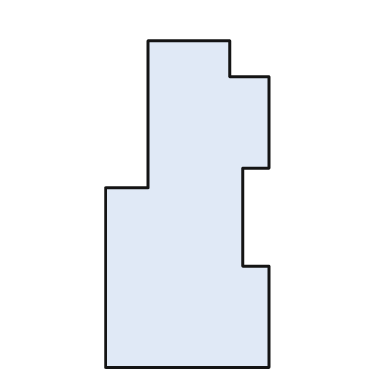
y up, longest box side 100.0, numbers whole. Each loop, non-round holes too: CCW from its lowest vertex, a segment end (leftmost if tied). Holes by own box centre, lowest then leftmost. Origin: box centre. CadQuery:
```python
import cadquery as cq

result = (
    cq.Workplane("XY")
    .moveTo(-25.0, -50.0)
    .lineTo(25.0, -50.0)
    .lineTo(25.0, -19.0)
    .lineTo(17.0, -19.0)
    .lineTo(17.0, 11.0)
    .lineTo(25.0, 11.0)
    .lineTo(25.0, 39.0)
    .lineTo(13.0, 39.0)
    .lineTo(13.0, 50.0)
    .lineTo(-12.0, 50.0)
    .lineTo(-12.0, 5.0)
    .lineTo(-25.0, 5.0)
    .close()
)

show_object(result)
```